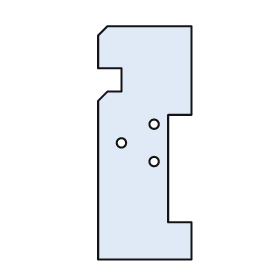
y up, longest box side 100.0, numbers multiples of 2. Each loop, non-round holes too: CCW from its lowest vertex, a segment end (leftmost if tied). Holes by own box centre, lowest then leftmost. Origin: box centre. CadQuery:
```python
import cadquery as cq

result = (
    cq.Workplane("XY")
    .moveTo(-20.0, -50.0)
    .lineTo(20.0, -50.0)
    .lineTo(20.0, -34.0)
    .lineTo(10.0, -34.0)
    .lineTo(10.0, 12.0)
    .lineTo(20.0, 12.0)
    .lineTo(20.0, 50.0)
    .lineTo(-16.0, 50.0)
    .lineTo(-20.0, 46.0)
    .lineTo(-20.0, 32.0)
    .lineTo(-10.0, 32.0)
    .lineTo(-10.0, 22.0)
    .lineTo(-16.0, 22.0)
    .lineTo(-20.0, 18.0)
    .close()
    .moveTo(4.0, -8.0)
    .circle(2.0)
    .moveTo(-10.0, 0.0)
    .circle(2.0)
    .moveTo(4.0, 8.0)
    .circle(2.0)
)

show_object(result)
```